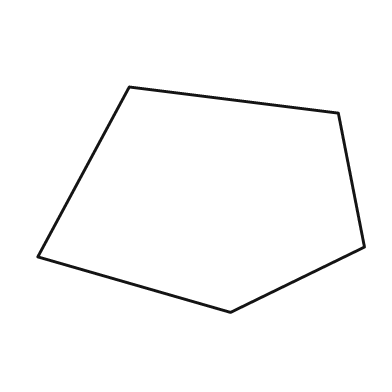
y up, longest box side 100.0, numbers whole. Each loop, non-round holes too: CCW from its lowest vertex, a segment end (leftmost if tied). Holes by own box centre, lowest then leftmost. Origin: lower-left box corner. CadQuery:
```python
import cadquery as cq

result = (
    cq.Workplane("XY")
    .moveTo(59.0, 0.0)
    .lineTo(100.0, 20.0)
    .lineTo(92.0, 61.0)
    .lineTo(28.0, 69.0)
    .lineTo(0.0, 17.0)
    .close()
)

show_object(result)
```